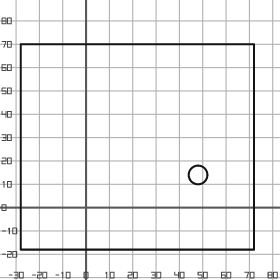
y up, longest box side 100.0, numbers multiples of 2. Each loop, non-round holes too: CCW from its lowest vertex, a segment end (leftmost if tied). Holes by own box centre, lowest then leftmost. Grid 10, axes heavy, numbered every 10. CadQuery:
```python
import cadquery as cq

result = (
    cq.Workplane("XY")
    .moveTo(-28.0, -18.0)
    .lineTo(72.0, -18.0)
    .lineTo(72.0, 70.0)
    .lineTo(-28.0, 70.0)
    .close()
    .moveTo(48.0, 14.0)
    .circle(4.0)
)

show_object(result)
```